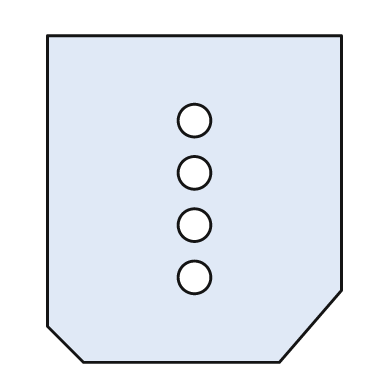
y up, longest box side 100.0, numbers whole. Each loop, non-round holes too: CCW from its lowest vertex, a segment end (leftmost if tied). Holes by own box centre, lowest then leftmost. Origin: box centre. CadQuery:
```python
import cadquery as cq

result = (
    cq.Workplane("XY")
    .moveTo(-34.0, -50.0)
    .lineTo(26.0, -50.0)
    .lineTo(45.0, -28.0)
    .lineTo(45.0, 50.0)
    .lineTo(-45.0, 50.0)
    .lineTo(-45.0, -39.0)
    .close()
    .moveTo(0.0, -24.0)
    .circle(5.0)
    .moveTo(0.0, -8.0)
    .circle(5.0)
    .moveTo(0.0, 8.0)
    .circle(5.0)
    .moveTo(0.0, 24.0)
    .circle(5.0)
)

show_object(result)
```